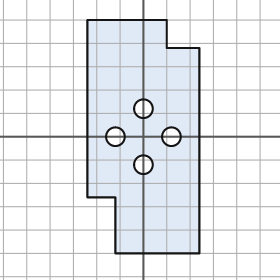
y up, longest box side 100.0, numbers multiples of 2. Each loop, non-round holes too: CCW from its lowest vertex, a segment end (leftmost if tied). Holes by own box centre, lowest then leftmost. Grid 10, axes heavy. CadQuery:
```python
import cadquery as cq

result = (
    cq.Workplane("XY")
    .moveTo(-12.0, -50.0)
    .lineTo(24.0, -50.0)
    .lineTo(24.0, 38.0)
    .lineTo(10.0, 38.0)
    .lineTo(10.0, 50.0)
    .lineTo(-24.0, 50.0)
    .lineTo(-24.0, -26.0)
    .lineTo(-12.0, -26.0)
    .close()
    .moveTo(0.0, -12.0)
    .circle(4.0)
    .moveTo(-12.0, 0.0)
    .circle(4.0)
    .moveTo(12.0, 0.0)
    .circle(4.0)
    .moveTo(0.0, 12.0)
    .circle(4.0)
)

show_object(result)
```